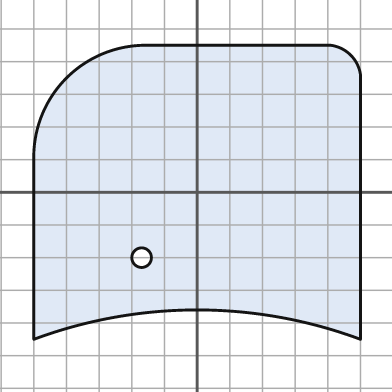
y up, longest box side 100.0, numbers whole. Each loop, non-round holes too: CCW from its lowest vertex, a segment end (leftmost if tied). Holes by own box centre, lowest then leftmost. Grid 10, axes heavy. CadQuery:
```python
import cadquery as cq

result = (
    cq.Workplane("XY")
    .moveTo(-50.0, -45.0)
    .threePointArc((0.0, -36.0), (50.0, -45.0))
    .lineTo(50.0, 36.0)
    .threePointArc((47.0, 42.0), (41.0, 45.0))
    .lineTo(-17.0, 45.0)
    .threePointArc((-40.0, 35.0), (-50.0, 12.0))
    .close()
    .moveTo(-17.0, -20.0)
    .circle(3.0)
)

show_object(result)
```